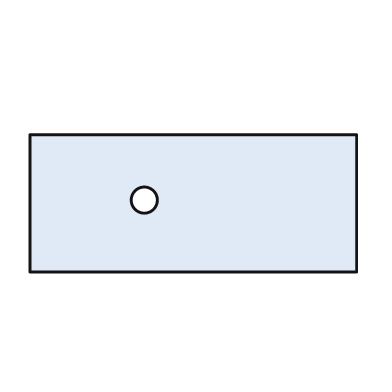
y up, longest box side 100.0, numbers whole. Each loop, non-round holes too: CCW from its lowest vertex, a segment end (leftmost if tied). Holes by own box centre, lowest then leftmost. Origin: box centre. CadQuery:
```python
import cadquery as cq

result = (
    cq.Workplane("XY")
    .moveTo(-50.0, -21.0)
    .lineTo(50.0, -21.0)
    .lineTo(50.0, 21.0)
    .lineTo(-50.0, 21.0)
    .close()
    .moveTo(-15.0, 1.0)
    .circle(4.0)
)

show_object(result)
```